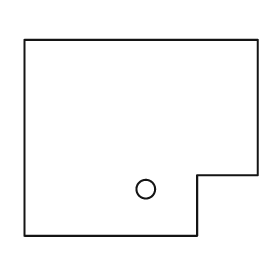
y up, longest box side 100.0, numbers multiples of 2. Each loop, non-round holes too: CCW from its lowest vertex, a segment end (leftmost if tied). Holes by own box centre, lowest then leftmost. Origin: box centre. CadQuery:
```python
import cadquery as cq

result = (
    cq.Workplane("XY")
    .moveTo(-50.0, -42.0)
    .lineTo(24.0, -42.0)
    .lineTo(24.0, -16.0)
    .lineTo(50.0, -16.0)
    .lineTo(50.0, 42.0)
    .lineTo(-50.0, 42.0)
    .close()
    .moveTo(2.0, -22.0)
    .circle(4.0)
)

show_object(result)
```